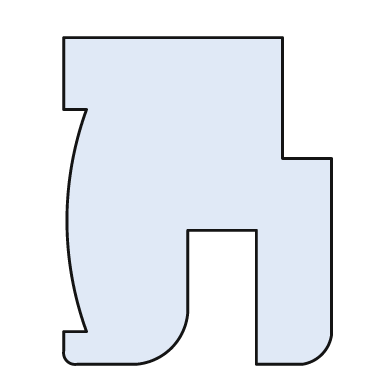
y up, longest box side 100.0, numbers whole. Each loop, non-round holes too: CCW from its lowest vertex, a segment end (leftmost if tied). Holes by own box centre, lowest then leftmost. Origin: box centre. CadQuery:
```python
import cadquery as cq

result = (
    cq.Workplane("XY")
    .moveTo(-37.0, -50.0)
    .lineTo(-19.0, -50.0)
    .threePointArc((-8.0, -45.0), (-3.0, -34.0))
    .lineTo(-3.0, -9.0)
    .lineTo(18.0, -9.0)
    .lineTo(18.0, -50.0)
    .lineTo(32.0, -50.0)
    .threePointArc((38.0, -47.0), (41.0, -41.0))
    .lineTo(41.0, 13.0)
    .lineTo(26.0, 13.0)
    .lineTo(26.0, 50.0)
    .lineTo(-41.0, 50.0)
    .lineTo(-41.0, 28.0)
    .lineTo(-34.0, 28.0)
    .threePointArc((-40.0, -6.0), (-34.0, -40.0))
    .lineTo(-41.0, -40.0)
    .lineTo(-41.0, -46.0)
    .threePointArc((-40.0, -49.0), (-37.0, -50.0))
    .close()
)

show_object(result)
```